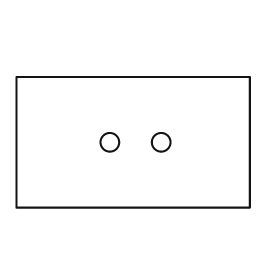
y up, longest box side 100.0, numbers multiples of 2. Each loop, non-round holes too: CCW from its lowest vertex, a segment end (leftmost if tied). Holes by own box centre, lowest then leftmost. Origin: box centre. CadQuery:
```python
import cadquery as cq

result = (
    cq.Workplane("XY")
    .moveTo(-50.0, -28.0)
    .lineTo(50.0, -28.0)
    .lineTo(50.0, 28.0)
    .lineTo(-50.0, 28.0)
    .close()
    .moveTo(-10.0, 0.0)
    .circle(4.0)
    .moveTo(12.0, 0.0)
    .circle(4.0)
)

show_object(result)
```